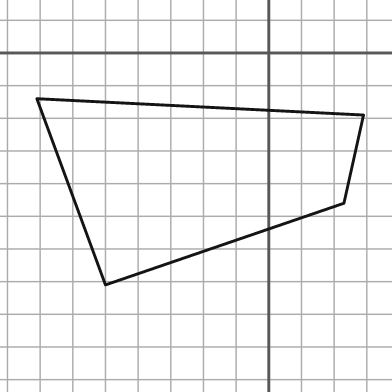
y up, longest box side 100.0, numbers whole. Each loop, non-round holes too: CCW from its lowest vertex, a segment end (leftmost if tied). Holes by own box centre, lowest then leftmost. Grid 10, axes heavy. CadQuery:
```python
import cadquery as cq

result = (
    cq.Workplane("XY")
    .moveTo(-50.0, -71.0)
    .lineTo(23.0, -46.0)
    .lineTo(29.0, -19.0)
    .lineTo(-71.0, -14.0)
    .close()
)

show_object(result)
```